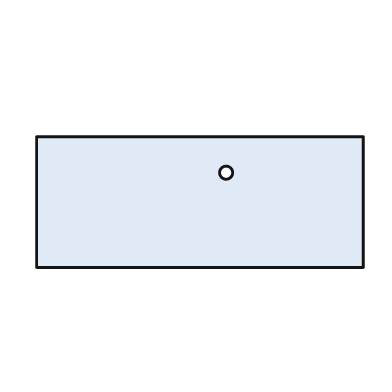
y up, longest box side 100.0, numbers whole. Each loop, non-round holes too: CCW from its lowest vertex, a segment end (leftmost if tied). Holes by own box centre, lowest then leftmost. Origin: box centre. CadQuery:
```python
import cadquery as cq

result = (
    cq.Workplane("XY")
    .moveTo(-50.0, -20.0)
    .lineTo(50.0, -20.0)
    .lineTo(50.0, 20.0)
    .lineTo(-50.0, 20.0)
    .close()
    .moveTo(8.0, 9.0)
    .circle(2.0)
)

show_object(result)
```